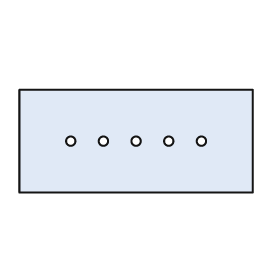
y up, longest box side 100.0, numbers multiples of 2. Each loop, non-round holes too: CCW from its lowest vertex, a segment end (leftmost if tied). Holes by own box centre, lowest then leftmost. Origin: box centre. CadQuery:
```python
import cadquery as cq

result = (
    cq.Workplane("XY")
    .moveTo(-50.0, -22.0)
    .lineTo(50.0, -22.0)
    .lineTo(50.0, 22.0)
    .lineTo(-50.0, 22.0)
    .close()
    .moveTo(-28.0, 0.0)
    .circle(2.0)
    .moveTo(-14.0, 0.0)
    .circle(2.0)
    .moveTo(0.0, 0.0)
    .circle(2.0)
    .moveTo(14.0, 0.0)
    .circle(2.0)
    .moveTo(28.0, 0.0)
    .circle(2.0)
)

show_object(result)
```